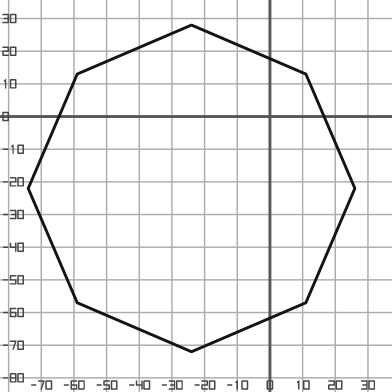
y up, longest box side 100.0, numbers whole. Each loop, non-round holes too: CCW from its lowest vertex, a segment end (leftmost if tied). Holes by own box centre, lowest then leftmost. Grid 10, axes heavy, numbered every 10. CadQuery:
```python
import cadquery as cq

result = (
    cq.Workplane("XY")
    .moveTo(-24.0, -72.0)
    .lineTo(11.0, -57.0)
    .lineTo(26.0, -22.0)
    .lineTo(11.0, 13.0)
    .lineTo(-24.0, 28.0)
    .lineTo(-59.0, 13.0)
    .lineTo(-74.0, -22.0)
    .lineTo(-59.0, -57.0)
    .close()
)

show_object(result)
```